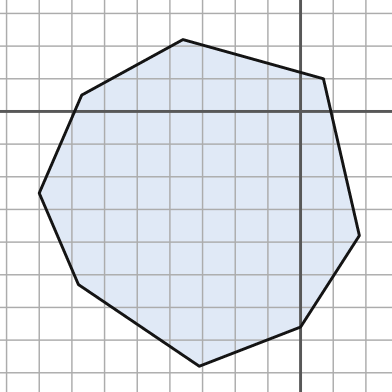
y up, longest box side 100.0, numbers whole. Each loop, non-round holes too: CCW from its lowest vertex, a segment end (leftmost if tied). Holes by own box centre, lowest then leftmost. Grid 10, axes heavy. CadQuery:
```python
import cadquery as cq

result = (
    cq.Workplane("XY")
    .moveTo(-31.0, -78.0)
    .lineTo(0.0, -66.0)
    .lineTo(18.0, -38.0)
    .lineTo(7.0, 10.0)
    .lineTo(-36.0, 22.0)
    .lineTo(-67.0, 5.0)
    .lineTo(-80.0, -25.0)
    .lineTo(-68.0, -53.0)
    .close()
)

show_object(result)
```